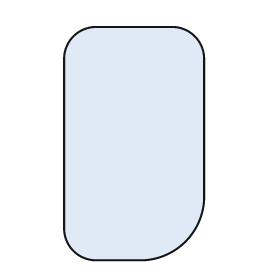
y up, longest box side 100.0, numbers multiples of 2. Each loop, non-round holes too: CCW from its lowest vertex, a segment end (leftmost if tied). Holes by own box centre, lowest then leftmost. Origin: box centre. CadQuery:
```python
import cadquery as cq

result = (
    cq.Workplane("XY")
    .moveTo(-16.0, -50.0)
    .lineTo(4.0, -50.0)
    .threePointArc((22.0, -42.0), (30.0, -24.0))
    .lineTo(30.0, 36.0)
    .threePointArc((26.0, 46.0), (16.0, 50.0))
    .lineTo(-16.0, 50.0)
    .threePointArc((-26.0, 46.0), (-30.0, 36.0))
    .lineTo(-30.0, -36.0)
    .threePointArc((-26.0, -46.0), (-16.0, -50.0))
    .close()
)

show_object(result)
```